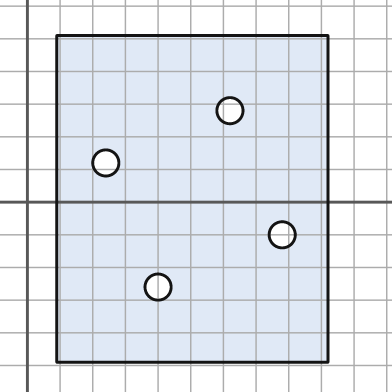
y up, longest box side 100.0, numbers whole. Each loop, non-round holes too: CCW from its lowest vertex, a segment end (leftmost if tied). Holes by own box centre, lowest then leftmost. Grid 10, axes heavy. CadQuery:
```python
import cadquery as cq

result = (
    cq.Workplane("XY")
    .moveTo(9.0, -49.0)
    .lineTo(92.0, -49.0)
    .lineTo(92.0, 51.0)
    .lineTo(9.0, 51.0)
    .close()
    .moveTo(40.0, -26.0)
    .circle(4.0)
    .moveTo(78.0, -10.0)
    .circle(4.0)
    .moveTo(24.0, 12.0)
    .circle(4.0)
    .moveTo(62.0, 28.0)
    .circle(4.0)
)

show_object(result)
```